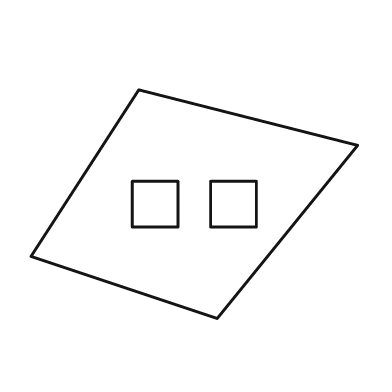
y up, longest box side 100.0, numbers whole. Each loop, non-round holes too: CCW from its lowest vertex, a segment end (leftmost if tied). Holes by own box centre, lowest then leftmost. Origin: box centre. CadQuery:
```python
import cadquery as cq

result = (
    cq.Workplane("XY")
    .moveTo(7.0, -35.0)
    .lineTo(50.0, 18.0)
    .lineTo(-17.0, 35.0)
    .lineTo(-50.0, -16.0)
    .close()
    .moveTo(-19.0, -7.0)
    .lineTo(-5.0, -7.0)
    .lineTo(-5.0, 7.0)
    .lineTo(-19.0, 7.0)
    .close()
    .moveTo(5.0, -7.0)
    .lineTo(19.0, -7.0)
    .lineTo(19.0, 7.0)
    .lineTo(5.0, 7.0)
    .close()
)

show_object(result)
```